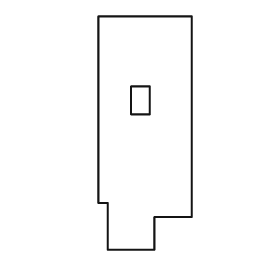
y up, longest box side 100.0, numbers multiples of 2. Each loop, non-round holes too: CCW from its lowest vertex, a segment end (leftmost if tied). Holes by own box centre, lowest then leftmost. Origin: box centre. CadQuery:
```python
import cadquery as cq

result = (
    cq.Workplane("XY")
    .moveTo(-16.0, -50.0)
    .lineTo(4.0, -50.0)
    .lineTo(4.0, -36.0)
    .lineTo(20.0, -36.0)
    .lineTo(20.0, 50.0)
    .lineTo(-20.0, 50.0)
    .lineTo(-20.0, -30.0)
    .lineTo(-16.0, -30.0)
    .close()
    .moveTo(-6.0, 8.0)
    .lineTo(2.0, 8.0)
    .lineTo(2.0, 20.0)
    .lineTo(-6.0, 20.0)
    .close()
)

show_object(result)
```